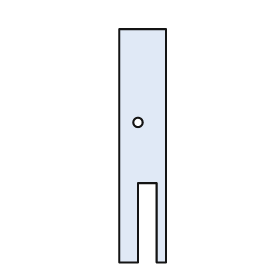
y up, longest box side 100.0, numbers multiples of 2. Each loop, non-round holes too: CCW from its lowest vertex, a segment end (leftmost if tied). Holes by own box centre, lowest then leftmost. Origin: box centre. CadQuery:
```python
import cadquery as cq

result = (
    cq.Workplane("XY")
    .moveTo(-10.0, -50.0)
    .lineTo(-2.0, -50.0)
    .lineTo(-2.0, -16.0)
    .lineTo(6.0, -16.0)
    .lineTo(6.0, -50.0)
    .lineTo(10.0, -50.0)
    .lineTo(10.0, 50.0)
    .lineTo(-10.0, 50.0)
    .close()
    .moveTo(-2.0, 10.0)
    .circle(2.0)
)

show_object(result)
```